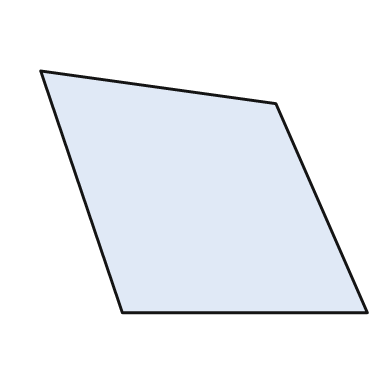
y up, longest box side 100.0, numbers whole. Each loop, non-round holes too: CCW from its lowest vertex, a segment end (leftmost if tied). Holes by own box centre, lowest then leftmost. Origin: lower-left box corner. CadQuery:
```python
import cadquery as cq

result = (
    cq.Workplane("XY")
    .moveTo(25.0, 0.0)
    .lineTo(100.0, 0.0)
    .lineTo(72.0, 64.0)
    .lineTo(0.0, 74.0)
    .close()
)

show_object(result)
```